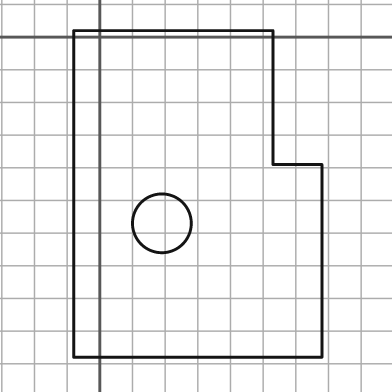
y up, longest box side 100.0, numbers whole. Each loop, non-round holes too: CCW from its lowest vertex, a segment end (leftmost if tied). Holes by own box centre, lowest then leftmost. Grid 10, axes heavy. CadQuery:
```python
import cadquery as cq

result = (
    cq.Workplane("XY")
    .moveTo(-8.0, -98.0)
    .lineTo(68.0, -98.0)
    .lineTo(68.0, -39.0)
    .lineTo(53.0, -39.0)
    .lineTo(53.0, 2.0)
    .lineTo(-8.0, 2.0)
    .close()
    .moveTo(19.0, -57.0)
    .circle(9.0)
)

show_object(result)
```